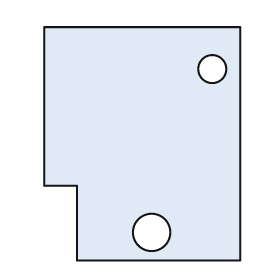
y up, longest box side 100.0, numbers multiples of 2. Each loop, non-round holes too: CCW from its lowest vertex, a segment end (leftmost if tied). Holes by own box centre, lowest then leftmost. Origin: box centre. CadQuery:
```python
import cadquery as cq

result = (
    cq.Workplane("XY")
    .moveTo(-28.0, -50.0)
    .lineTo(42.0, -50.0)
    .lineTo(42.0, 50.0)
    .lineTo(-42.0, 50.0)
    .lineTo(-42.0, -18.0)
    .lineTo(-28.0, -18.0)
    .close()
    .moveTo(4.0, -38.0)
    .circle(8.0)
    .moveTo(30.0, 32.0)
    .circle(6.0)
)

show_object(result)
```